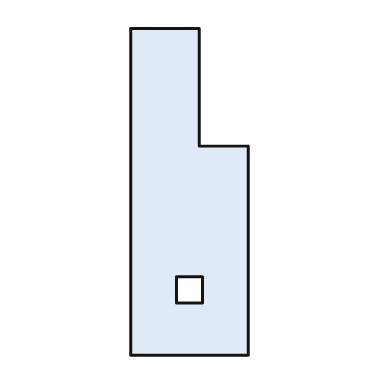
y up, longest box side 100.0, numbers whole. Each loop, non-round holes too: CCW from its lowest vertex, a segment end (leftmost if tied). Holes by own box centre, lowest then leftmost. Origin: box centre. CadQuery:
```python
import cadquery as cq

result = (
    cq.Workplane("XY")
    .moveTo(-18.0, -50.0)
    .lineTo(18.0, -50.0)
    .lineTo(18.0, 14.0)
    .lineTo(3.0, 14.0)
    .lineTo(3.0, 50.0)
    .lineTo(-18.0, 50.0)
    .close()
    .moveTo(-4.0, -34.0)
    .lineTo(4.0, -34.0)
    .lineTo(4.0, -26.0)
    .lineTo(-4.0, -26.0)
    .close()
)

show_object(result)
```